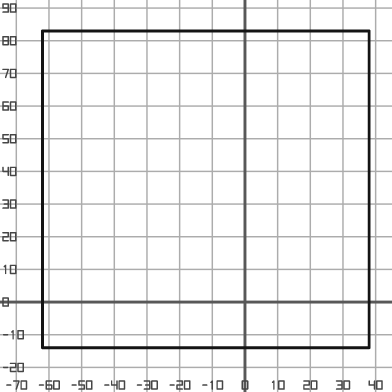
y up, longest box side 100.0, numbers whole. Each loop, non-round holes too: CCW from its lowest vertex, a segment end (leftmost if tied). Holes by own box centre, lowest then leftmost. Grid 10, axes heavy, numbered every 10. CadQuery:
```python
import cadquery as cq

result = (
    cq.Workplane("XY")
    .moveTo(-62.0, -14.0)
    .lineTo(38.0, -14.0)
    .lineTo(38.0, 83.0)
    .lineTo(-62.0, 83.0)
    .close()
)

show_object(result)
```